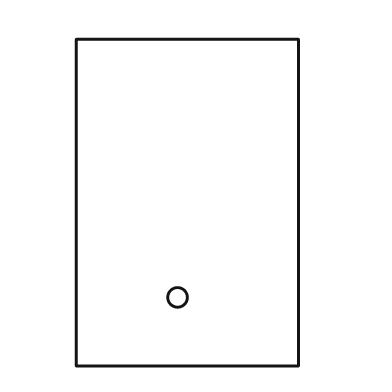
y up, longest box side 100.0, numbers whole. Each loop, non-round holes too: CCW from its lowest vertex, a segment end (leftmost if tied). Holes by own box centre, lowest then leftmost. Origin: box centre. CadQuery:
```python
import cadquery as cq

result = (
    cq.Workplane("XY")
    .moveTo(-34.0, -50.0)
    .lineTo(34.0, -50.0)
    .lineTo(34.0, 50.0)
    .lineTo(-34.0, 50.0)
    .close()
    .moveTo(-3.0, -29.0)
    .circle(3.0)
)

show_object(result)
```